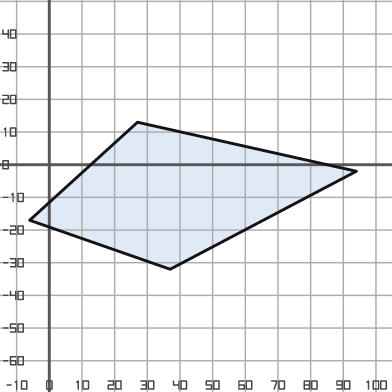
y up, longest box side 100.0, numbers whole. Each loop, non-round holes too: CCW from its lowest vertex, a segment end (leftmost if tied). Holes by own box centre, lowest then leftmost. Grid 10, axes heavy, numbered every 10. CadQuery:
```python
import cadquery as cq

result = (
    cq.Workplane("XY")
    .moveTo(37.0, -32.0)
    .lineTo(94.0, -2.0)
    .lineTo(27.0, 13.0)
    .lineTo(-6.0, -17.0)
    .close()
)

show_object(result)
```